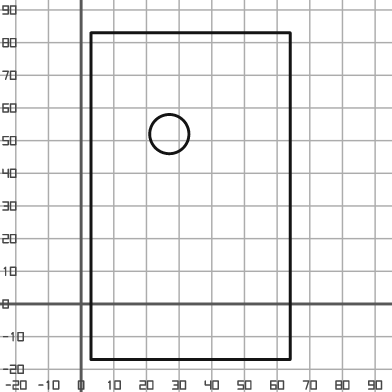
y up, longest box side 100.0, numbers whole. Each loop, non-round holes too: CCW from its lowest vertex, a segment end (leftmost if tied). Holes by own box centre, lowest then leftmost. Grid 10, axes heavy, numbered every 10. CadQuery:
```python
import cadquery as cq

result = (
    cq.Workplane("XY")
    .moveTo(3.0, -17.0)
    .lineTo(64.0, -17.0)
    .lineTo(64.0, 83.0)
    .lineTo(3.0, 83.0)
    .close()
    .moveTo(27.0, 52.0)
    .circle(6.0)
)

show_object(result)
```